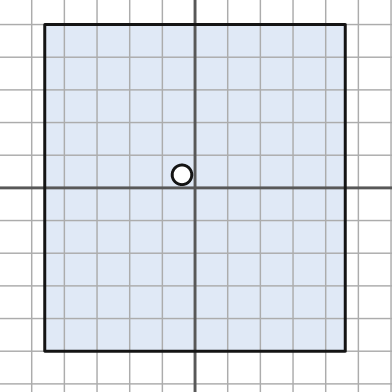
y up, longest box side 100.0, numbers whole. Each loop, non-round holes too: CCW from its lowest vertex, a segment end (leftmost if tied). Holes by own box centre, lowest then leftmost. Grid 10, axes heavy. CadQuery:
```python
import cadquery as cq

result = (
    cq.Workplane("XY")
    .moveTo(-46.0, -50.0)
    .lineTo(46.0, -50.0)
    .lineTo(46.0, 50.0)
    .lineTo(-46.0, 50.0)
    .close()
    .moveTo(-4.0, 4.0)
    .circle(3.0)
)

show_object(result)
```